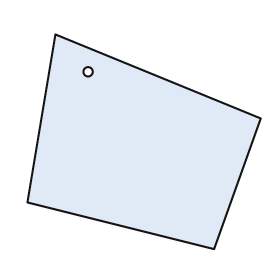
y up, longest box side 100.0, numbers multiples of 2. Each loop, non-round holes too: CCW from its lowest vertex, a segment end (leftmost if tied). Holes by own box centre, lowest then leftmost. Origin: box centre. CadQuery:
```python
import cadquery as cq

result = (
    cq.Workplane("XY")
    .moveTo(30.0, -46.0)
    .lineTo(50.0, 10.0)
    .lineTo(-38.0, 46.0)
    .lineTo(-50.0, -26.0)
    .close()
    .moveTo(-24.0, 30.0)
    .circle(2.0)
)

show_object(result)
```